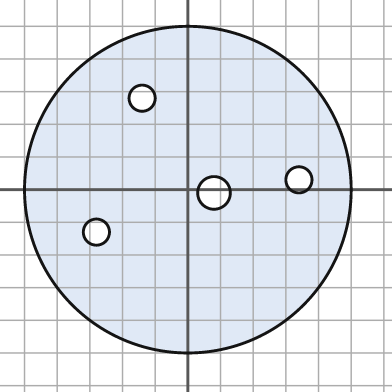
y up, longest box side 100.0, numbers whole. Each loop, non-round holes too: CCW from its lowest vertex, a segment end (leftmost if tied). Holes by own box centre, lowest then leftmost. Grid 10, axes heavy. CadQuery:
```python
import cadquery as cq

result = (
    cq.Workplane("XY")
    .moveTo(0.0, 0.0)
    .circle(50.0)
    .moveTo(-28.0, -13.0)
    .circle(4.0)
    .moveTo(8.0, -1.0)
    .circle(5.0)
    .moveTo(34.0, 3.0)
    .circle(4.0)
    .moveTo(-14.0, 28.0)
    .circle(4.0)
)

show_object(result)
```